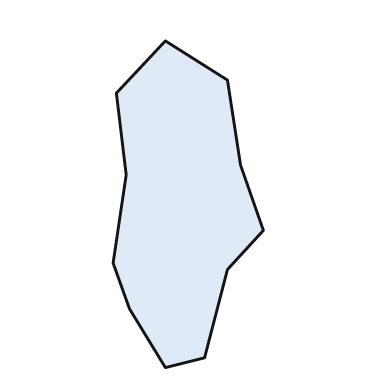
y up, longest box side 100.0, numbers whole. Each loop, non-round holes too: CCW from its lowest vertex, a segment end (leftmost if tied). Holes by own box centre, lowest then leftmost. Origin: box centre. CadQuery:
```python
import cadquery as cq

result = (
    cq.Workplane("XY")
    .moveTo(-7.0, -50.0)
    .lineTo(5.0, -47.0)
    .lineTo(12.0, -20.0)
    .lineTo(23.0, -8.0)
    .lineTo(16.0, 12.0)
    .lineTo(12.0, 38.0)
    .lineTo(-7.0, 50.0)
    .lineTo(-22.0, 34.0)
    .lineTo(-19.0, 9.0)
    .lineTo(-23.0, -18.0)
    .lineTo(-18.0, -32.0)
    .close()
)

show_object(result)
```